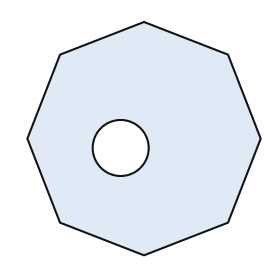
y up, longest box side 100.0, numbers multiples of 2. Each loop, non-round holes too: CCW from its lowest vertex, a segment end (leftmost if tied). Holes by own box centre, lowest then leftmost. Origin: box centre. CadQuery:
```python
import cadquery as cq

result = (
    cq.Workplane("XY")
    .moveTo(0.0, -50.0)
    .lineTo(36.0, -36.0)
    .lineTo(50.0, 0.0)
    .lineTo(36.0, 36.0)
    .lineTo(0.0, 50.0)
    .lineTo(-36.0, 36.0)
    .lineTo(-50.0, 0.0)
    .lineTo(-36.0, -36.0)
    .close()
    .moveTo(-10.0, -4.0)
    .circle(12.0)
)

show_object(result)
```